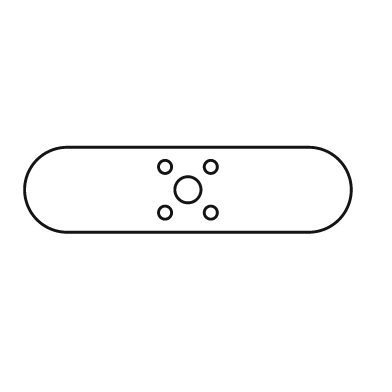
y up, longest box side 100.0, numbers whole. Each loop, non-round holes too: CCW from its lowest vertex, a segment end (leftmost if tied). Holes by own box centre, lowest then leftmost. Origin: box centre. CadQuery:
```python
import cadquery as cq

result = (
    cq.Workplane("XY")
    .moveTo(-37.0, -13.0)
    .lineTo(37.0, -13.0)
    .threePointArc((50.0, 0.0), (37.0, 13.0))
    .lineTo(-37.0, 13.0)
    .threePointArc((-50.0, 0.0), (-37.0, -13.0))
    .close()
    .moveTo(-7.0, -7.0)
    .circle(2.0)
    .moveTo(7.0, -7.0)
    .circle(2.0)
    .moveTo(0.0, 0.0)
    .circle(4.0)
    .moveTo(-7.0, 7.0)
    .circle(2.0)
    .moveTo(7.0, 7.0)
    .circle(2.0)
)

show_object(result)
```